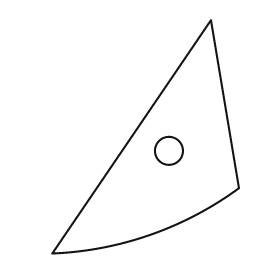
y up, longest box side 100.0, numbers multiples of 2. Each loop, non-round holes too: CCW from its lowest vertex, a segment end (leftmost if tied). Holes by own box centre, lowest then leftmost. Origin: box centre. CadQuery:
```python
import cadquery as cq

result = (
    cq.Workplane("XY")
    .moveTo(-40.0, -50.0)
    .threePointArc((2.0, -42.0), (40.0, -22.0))
    .lineTo(28.0, 50.0)
    .close()
    .moveTo(10.0, -6.0)
    .circle(6.0)
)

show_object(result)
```